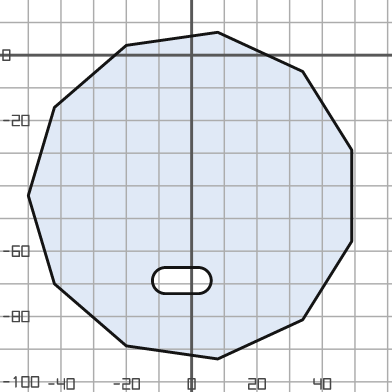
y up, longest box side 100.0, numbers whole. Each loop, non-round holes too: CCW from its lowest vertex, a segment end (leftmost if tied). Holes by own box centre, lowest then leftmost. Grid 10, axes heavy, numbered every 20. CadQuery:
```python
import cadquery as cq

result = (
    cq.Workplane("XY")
    .moveTo(8.0, -93.0)
    .lineTo(34.0, -81.0)
    .lineTo(49.0, -57.0)
    .lineTo(49.0, -29.0)
    .lineTo(34.0, -5.0)
    .lineTo(8.0, 7.0)
    .lineTo(-20.0, 3.0)
    .lineTo(-42.0, -16.0)
    .lineTo(-50.0, -43.0)
    .lineTo(-42.0, -70.0)
    .lineTo(-20.0, -89.0)
    .close()
    .moveTo(-8.0, -73.0)
    .lineTo(2.0, -73.0)
    .threePointArc((6.0, -69.0), (2.0, -65.0))
    .lineTo(-8.0, -65.0)
    .threePointArc((-12.0, -69.0), (-8.0, -73.0))
    .close()
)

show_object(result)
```